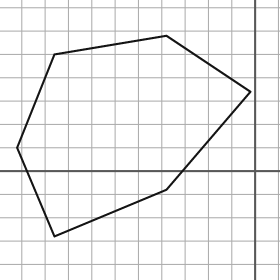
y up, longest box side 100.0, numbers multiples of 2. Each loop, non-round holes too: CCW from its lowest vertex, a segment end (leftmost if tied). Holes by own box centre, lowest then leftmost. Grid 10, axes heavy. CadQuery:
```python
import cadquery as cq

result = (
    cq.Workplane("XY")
    .moveTo(-86.0, -28.0)
    .lineTo(-38.0, -8.0)
    .lineTo(-2.0, 34.0)
    .lineTo(-38.0, 58.0)
    .lineTo(-86.0, 50.0)
    .lineTo(-102.0, 10.0)
    .close()
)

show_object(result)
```